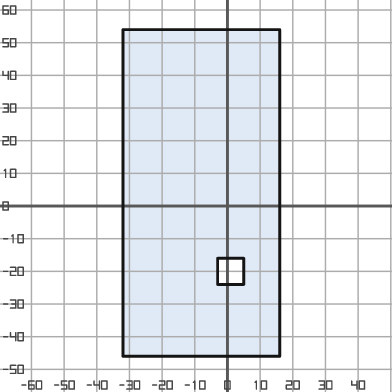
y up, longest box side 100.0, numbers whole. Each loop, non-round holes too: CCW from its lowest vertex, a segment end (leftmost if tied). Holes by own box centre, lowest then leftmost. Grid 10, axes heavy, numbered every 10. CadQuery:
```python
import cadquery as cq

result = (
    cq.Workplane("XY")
    .moveTo(-32.0, -46.0)
    .lineTo(16.0, -46.0)
    .lineTo(16.0, 54.0)
    .lineTo(-32.0, 54.0)
    .close()
    .moveTo(-3.0, -24.0)
    .lineTo(5.0, -24.0)
    .lineTo(5.0, -16.0)
    .lineTo(-3.0, -16.0)
    .close()
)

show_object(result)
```